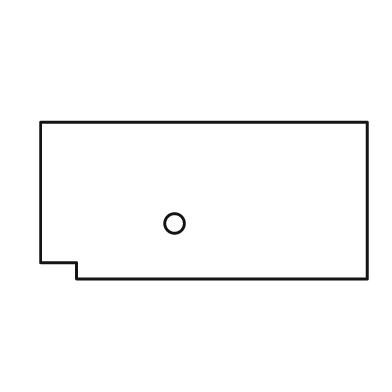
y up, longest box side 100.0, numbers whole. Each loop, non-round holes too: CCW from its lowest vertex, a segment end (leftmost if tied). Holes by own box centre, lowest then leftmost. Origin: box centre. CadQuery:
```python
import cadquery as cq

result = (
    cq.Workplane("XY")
    .moveTo(-39.0, -24.0)
    .lineTo(50.0, -24.0)
    .lineTo(50.0, 24.0)
    .lineTo(-50.0, 24.0)
    .lineTo(-50.0, -19.0)
    .lineTo(-39.0, -19.0)
    .close()
    .moveTo(-9.0, -7.0)
    .circle(3.0)
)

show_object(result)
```